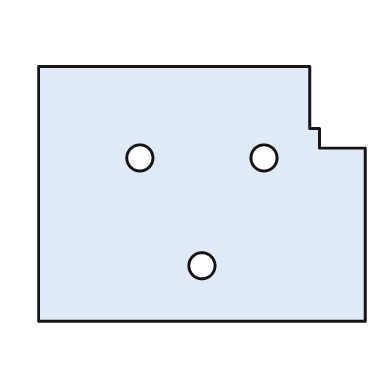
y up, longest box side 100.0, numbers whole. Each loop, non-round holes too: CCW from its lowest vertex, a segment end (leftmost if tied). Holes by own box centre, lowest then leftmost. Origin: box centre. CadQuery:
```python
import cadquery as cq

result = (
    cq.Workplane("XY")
    .moveTo(-50.0, -39.0)
    .lineTo(50.0, -39.0)
    .lineTo(50.0, 14.0)
    .lineTo(36.0, 14.0)
    .lineTo(36.0, 20.0)
    .lineTo(33.0, 20.0)
    .lineTo(33.0, 39.0)
    .lineTo(-50.0, 39.0)
    .close()
    .moveTo(0.0, -22.0)
    .circle(4.0)
    .moveTo(-19.0, 11.0)
    .circle(4.0)
    .moveTo(19.0, 11.0)
    .circle(4.0)
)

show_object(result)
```